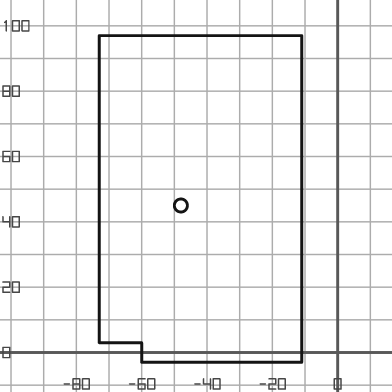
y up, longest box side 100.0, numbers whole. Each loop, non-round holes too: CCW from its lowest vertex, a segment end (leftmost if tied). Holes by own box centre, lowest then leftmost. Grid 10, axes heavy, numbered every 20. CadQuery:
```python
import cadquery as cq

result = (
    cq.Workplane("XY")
    .moveTo(-60.0, -3.0)
    .lineTo(-11.0, -3.0)
    .lineTo(-11.0, 97.0)
    .lineTo(-73.0, 97.0)
    .lineTo(-73.0, 3.0)
    .lineTo(-60.0, 3.0)
    .close()
    .moveTo(-48.0, 45.0)
    .circle(2.0)
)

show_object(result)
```